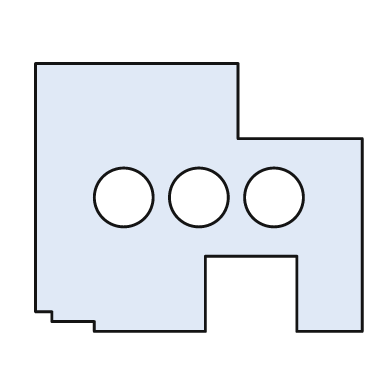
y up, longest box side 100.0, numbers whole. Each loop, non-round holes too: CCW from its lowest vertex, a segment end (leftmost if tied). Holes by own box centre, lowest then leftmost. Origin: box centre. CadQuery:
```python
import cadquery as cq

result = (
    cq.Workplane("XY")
    .moveTo(-32.0, -41.0)
    .lineTo(2.0, -41.0)
    .lineTo(2.0, -18.0)
    .lineTo(30.0, -18.0)
    .lineTo(30.0, -41.0)
    .lineTo(50.0, -41.0)
    .lineTo(50.0, 18.0)
    .lineTo(12.0, 18.0)
    .lineTo(12.0, 41.0)
    .lineTo(-50.0, 41.0)
    .lineTo(-50.0, -35.0)
    .lineTo(-45.0, -35.0)
    .lineTo(-45.0, -38.0)
    .lineTo(-32.0, -38.0)
    .close()
    .moveTo(-23.0, 0.0)
    .circle(9.0)
    .moveTo(0.0, 0.0)
    .circle(9.0)
    .moveTo(23.0, 0.0)
    .circle(9.0)
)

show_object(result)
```